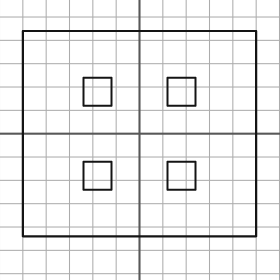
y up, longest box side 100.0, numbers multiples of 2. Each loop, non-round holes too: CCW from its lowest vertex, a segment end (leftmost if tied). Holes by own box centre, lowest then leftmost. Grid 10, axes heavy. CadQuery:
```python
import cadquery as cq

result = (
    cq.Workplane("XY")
    .moveTo(-50.0, -44.0)
    .lineTo(50.0, -44.0)
    .lineTo(50.0, 44.0)
    .lineTo(-50.0, 44.0)
    .close()
    .moveTo(-24.0, -24.0)
    .lineTo(-12.0, -24.0)
    .lineTo(-12.0, -12.0)
    .lineTo(-24.0, -12.0)
    .close()
    .moveTo(12.0, -24.0)
    .lineTo(24.0, -24.0)
    .lineTo(24.0, -12.0)
    .lineTo(12.0, -12.0)
    .close()
    .moveTo(-24.0, 12.0)
    .lineTo(-12.0, 12.0)
    .lineTo(-12.0, 24.0)
    .lineTo(-24.0, 24.0)
    .close()
    .moveTo(12.0, 12.0)
    .lineTo(24.0, 12.0)
    .lineTo(24.0, 24.0)
    .lineTo(12.0, 24.0)
    .close()
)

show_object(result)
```